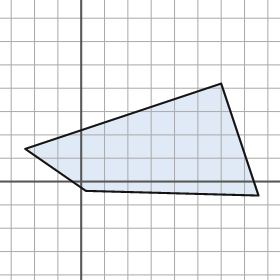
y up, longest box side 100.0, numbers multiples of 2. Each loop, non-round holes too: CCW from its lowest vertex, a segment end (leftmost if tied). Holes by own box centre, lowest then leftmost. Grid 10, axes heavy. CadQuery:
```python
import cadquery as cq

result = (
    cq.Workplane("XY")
    .moveTo(76.0, -6.0)
    .lineTo(60.0, 42.0)
    .lineTo(-24.0, 14.0)
    .lineTo(2.0, -4.0)
    .close()
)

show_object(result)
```